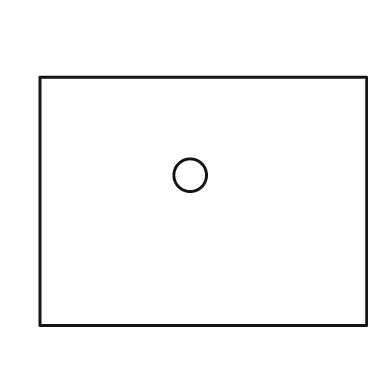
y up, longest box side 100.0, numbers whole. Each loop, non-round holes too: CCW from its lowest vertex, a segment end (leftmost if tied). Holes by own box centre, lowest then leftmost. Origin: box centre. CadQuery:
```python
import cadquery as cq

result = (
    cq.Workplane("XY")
    .moveTo(-50.0, -38.0)
    .lineTo(50.0, -38.0)
    .lineTo(50.0, 38.0)
    .lineTo(-50.0, 38.0)
    .close()
    .moveTo(-4.0, 8.0)
    .circle(5.0)
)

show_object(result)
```